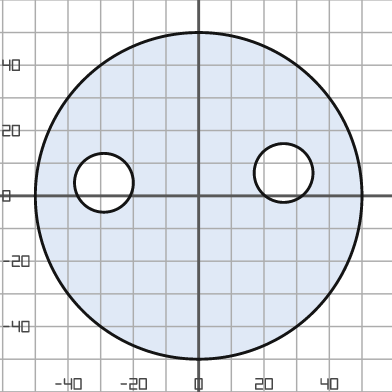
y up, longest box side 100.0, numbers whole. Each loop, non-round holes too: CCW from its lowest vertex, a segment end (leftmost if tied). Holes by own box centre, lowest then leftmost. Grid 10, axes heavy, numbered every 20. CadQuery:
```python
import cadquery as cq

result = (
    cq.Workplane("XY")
    .moveTo(0.0, 0.0)
    .circle(50.0)
    .moveTo(-29.0, 4.0)
    .circle(9.0)
    .moveTo(26.0, 7.0)
    .circle(9.0)
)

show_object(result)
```